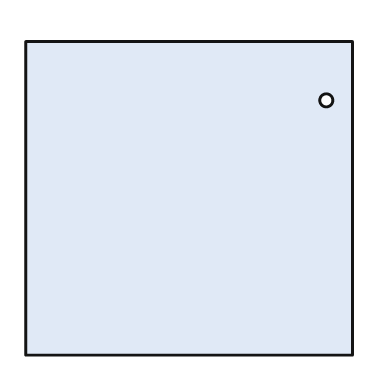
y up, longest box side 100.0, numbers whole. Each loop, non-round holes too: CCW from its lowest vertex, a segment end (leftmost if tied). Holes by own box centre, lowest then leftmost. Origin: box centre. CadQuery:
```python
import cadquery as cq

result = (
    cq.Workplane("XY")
    .moveTo(-50.0, -48.0)
    .lineTo(50.0, -48.0)
    .lineTo(50.0, 48.0)
    .lineTo(-50.0, 48.0)
    .close()
    .moveTo(42.0, 30.0)
    .circle(2.0)
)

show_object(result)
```